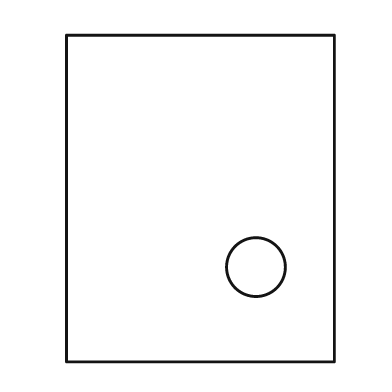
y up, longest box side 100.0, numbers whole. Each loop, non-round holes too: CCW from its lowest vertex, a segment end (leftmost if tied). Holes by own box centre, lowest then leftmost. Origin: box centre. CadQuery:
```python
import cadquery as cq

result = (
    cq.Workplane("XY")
    .moveTo(-41.0, -50.0)
    .lineTo(41.0, -50.0)
    .lineTo(41.0, 50.0)
    .lineTo(-41.0, 50.0)
    .close()
    .moveTo(17.0, -21.0)
    .circle(9.0)
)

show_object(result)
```